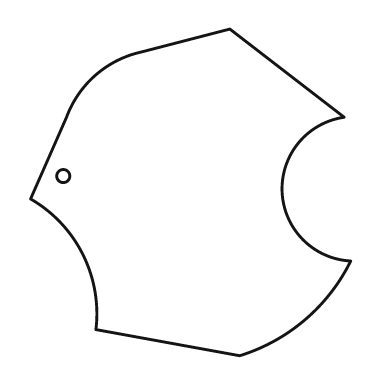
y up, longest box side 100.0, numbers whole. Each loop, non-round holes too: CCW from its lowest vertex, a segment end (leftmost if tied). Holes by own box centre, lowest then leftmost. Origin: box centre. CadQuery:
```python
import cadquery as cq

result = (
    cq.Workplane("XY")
    .moveTo(15.0, -50.0)
    .threePointArc((35.0, -39.0), (49.0, -21.0))
    .threePointArc((28.0, 0.0), (47.0, 23.0))
    .lineTo(12.0, 50.0)
    .lineTo(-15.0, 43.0)
    .threePointArc((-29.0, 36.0), (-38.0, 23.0))
    .lineTo(-49.0, -2.0)
    .threePointArc((-33.0, -19.0), (-29.0, -42.0))
    .close()
    .moveTo(-39.0, 5.0)
    .circle(2.0)
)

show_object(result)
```